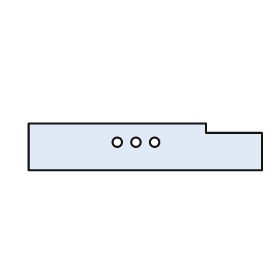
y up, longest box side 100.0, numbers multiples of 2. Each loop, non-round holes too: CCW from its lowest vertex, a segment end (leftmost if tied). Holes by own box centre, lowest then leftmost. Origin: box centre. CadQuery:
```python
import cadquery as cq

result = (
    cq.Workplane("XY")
    .moveTo(-50.0, -10.0)
    .lineTo(50.0, -10.0)
    .lineTo(50.0, 6.0)
    .lineTo(26.0, 6.0)
    .lineTo(26.0, 10.0)
    .lineTo(-50.0, 10.0)
    .close()
    .moveTo(-12.0, 2.0)
    .circle(2.0)
    .moveTo(-4.0, 2.0)
    .circle(2.0)
    .moveTo(4.0, 2.0)
    .circle(2.0)
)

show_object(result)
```